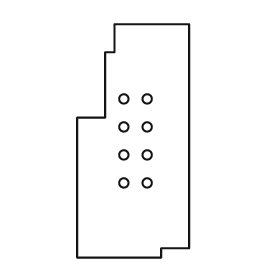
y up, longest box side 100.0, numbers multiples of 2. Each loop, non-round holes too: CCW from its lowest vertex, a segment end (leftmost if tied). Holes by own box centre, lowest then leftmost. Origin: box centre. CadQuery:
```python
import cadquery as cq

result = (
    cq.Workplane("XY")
    .moveTo(-24.0, -50.0)
    .lineTo(12.0, -50.0)
    .lineTo(12.0, -46.0)
    .lineTo(24.0, -46.0)
    .lineTo(24.0, 50.0)
    .lineTo(-8.0, 50.0)
    .lineTo(-8.0, 38.0)
    .lineTo(-12.0, 38.0)
    .lineTo(-12.0, 10.0)
    .lineTo(-24.0, 10.0)
    .close()
    .moveTo(-4.0, -18.0)
    .circle(2.0)
    .moveTo(6.0, -18.0)
    .circle(2.0)
    .moveTo(-4.0, -6.0)
    .circle(2.0)
    .moveTo(6.0, -6.0)
    .circle(2.0)
    .moveTo(-4.0, 6.0)
    .circle(2.0)
    .moveTo(6.0, 6.0)
    .circle(2.0)
    .moveTo(-4.0, 18.0)
    .circle(2.0)
    .moveTo(6.0, 18.0)
    .circle(2.0)
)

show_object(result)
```